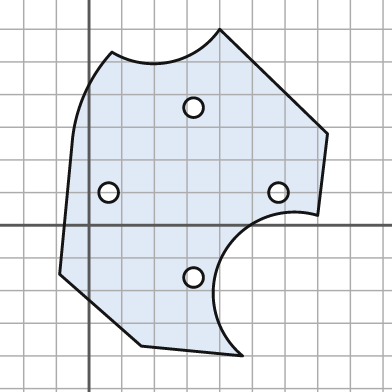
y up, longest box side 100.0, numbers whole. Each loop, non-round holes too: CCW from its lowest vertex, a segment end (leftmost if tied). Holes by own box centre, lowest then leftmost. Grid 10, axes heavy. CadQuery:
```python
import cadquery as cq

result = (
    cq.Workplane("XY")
    .moveTo(47.0, -40.0)
    .threePointArc((41.0, -9.0), (70.0, 3.0))
    .lineTo(73.0, 28.0)
    .lineTo(40.0, 60.0)
    .threePointArc((25.0, 50.0), (7.0, 53.0))
    .threePointArc((-1.0, 41.0), (-5.0, 27.0))
    .lineTo(-9.0, -15.0)
    .lineTo(16.0, -37.0)
    .close()
    .moveTo(32.0, -16.0)
    .circle(3.0)
    .moveTo(6.0, 10.0)
    .circle(3.0)
    .moveTo(58.0, 10.0)
    .circle(3.0)
    .moveTo(32.0, 36.0)
    .circle(3.0)
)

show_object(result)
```